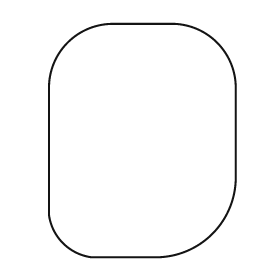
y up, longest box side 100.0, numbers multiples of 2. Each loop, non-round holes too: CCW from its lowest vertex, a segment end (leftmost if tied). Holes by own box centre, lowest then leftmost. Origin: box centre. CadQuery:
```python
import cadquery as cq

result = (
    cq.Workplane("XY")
    .moveTo(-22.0, -50.0)
    .lineTo(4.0, -50.0)
    .threePointArc((30.0, -40.0), (40.0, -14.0))
    .lineTo(40.0, 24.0)
    .threePointArc((32.0, 42.0), (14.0, 50.0))
    .lineTo(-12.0, 50.0)
    .threePointArc((-32.0, 42.0), (-40.0, 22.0))
    .lineTo(-40.0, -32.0)
    .threePointArc((-34.0, -44.0), (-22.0, -50.0))
    .close()
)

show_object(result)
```